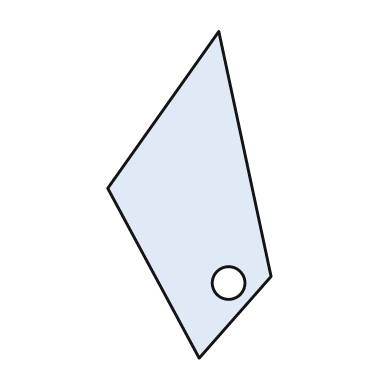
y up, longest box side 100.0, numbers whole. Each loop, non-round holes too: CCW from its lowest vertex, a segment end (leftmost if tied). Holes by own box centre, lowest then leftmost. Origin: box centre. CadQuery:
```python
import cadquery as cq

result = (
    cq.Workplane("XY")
    .moveTo(3.0, -50.0)
    .lineTo(25.0, -25.0)
    .lineTo(9.0, 50.0)
    .lineTo(-25.0, 2.0)
    .close()
    .moveTo(12.0, -27.0)
    .circle(5.0)
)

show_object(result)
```